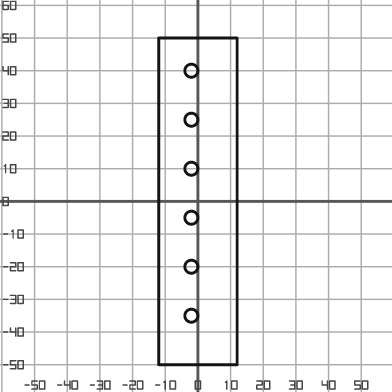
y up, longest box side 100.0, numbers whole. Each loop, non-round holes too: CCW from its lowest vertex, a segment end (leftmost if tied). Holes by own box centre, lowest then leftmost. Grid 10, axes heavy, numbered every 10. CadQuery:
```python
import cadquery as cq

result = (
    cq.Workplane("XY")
    .moveTo(-12.0, -50.0)
    .lineTo(12.0, -50.0)
    .lineTo(12.0, 50.0)
    .lineTo(-12.0, 50.0)
    .close()
    .moveTo(-2.0, -35.0)
    .circle(2.0)
    .moveTo(-2.0, -20.0)
    .circle(2.0)
    .moveTo(-2.0, -5.0)
    .circle(2.0)
    .moveTo(-2.0, 10.0)
    .circle(2.0)
    .moveTo(-2.0, 25.0)
    .circle(2.0)
    .moveTo(-2.0, 40.0)
    .circle(2.0)
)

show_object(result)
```